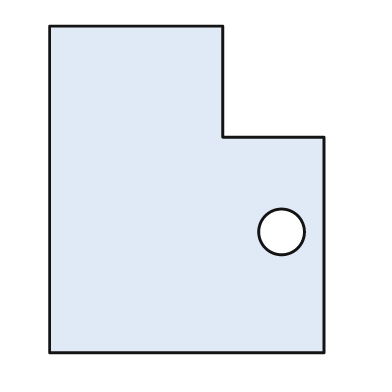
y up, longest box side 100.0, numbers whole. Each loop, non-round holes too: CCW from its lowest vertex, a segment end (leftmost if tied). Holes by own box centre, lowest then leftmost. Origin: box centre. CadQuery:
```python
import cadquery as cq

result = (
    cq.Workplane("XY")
    .moveTo(-42.0, -50.0)
    .lineTo(42.0, -50.0)
    .lineTo(42.0, 16.0)
    .lineTo(11.0, 16.0)
    .lineTo(11.0, 50.0)
    .lineTo(-42.0, 50.0)
    .close()
    .moveTo(29.0, -13.0)
    .circle(7.0)
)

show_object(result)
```